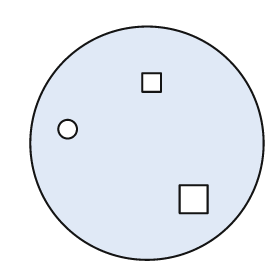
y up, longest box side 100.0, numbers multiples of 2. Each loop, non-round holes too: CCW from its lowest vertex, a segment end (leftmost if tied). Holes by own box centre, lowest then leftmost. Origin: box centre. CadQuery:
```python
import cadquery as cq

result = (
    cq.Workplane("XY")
    .moveTo(0.0, 0.0)
    .circle(50.0)
    .moveTo(14.0, -30.0)
    .lineTo(26.0, -30.0)
    .lineTo(26.0, -18.0)
    .lineTo(14.0, -18.0)
    .close()
    .moveTo(-34.0, 6.0)
    .circle(4.0)
    .moveTo(-2.0, 22.0)
    .lineTo(6.0, 22.0)
    .lineTo(6.0, 30.0)
    .lineTo(-2.0, 30.0)
    .close()
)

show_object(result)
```